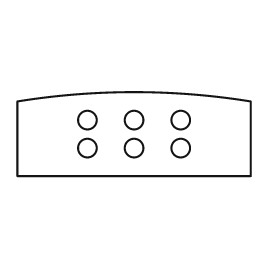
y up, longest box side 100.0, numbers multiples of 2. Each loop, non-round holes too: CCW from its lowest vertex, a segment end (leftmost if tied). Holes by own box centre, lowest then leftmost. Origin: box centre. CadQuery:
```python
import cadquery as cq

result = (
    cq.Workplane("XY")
    .moveTo(-50.0, -18.0)
    .lineTo(50.0, -18.0)
    .lineTo(50.0, 14.0)
    .threePointArc((0.0, 18.0), (-50.0, 14.0))
    .close()
    .moveTo(-20.0, -6.0)
    .circle(4.0)
    .moveTo(0.0, -6.0)
    .circle(4.0)
    .moveTo(20.0, -6.0)
    .circle(4.0)
    .moveTo(-20.0, 6.0)
    .circle(4.0)
    .moveTo(0.0, 6.0)
    .circle(4.0)
    .moveTo(20.0, 6.0)
    .circle(4.0)
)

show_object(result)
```